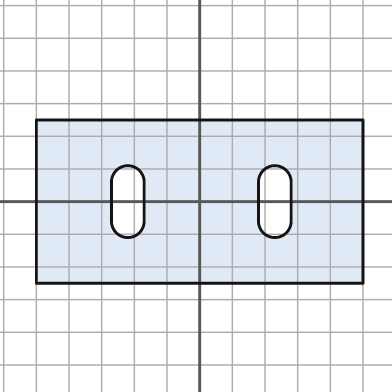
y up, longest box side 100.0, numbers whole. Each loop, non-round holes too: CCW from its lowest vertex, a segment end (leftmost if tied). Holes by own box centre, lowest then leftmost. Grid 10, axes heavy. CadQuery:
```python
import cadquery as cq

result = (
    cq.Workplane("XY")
    .moveTo(-50.0, -25.0)
    .lineTo(50.0, -25.0)
    .lineTo(50.0, 25.0)
    .lineTo(-50.0, 25.0)
    .close()
    .moveTo(-27.0, -6.0)
    .threePointArc((-22.0, -11.0), (-17.0, -6.0))
    .lineTo(-17.0, 6.0)
    .threePointArc((-22.0, 11.0), (-27.0, 6.0))
    .close()
    .moveTo(18.0, -6.0)
    .threePointArc((23.0, -11.0), (28.0, -6.0))
    .lineTo(28.0, 6.0)
    .threePointArc((23.0, 11.0), (18.0, 6.0))
    .close()
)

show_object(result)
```